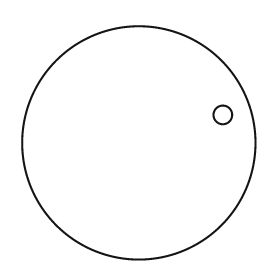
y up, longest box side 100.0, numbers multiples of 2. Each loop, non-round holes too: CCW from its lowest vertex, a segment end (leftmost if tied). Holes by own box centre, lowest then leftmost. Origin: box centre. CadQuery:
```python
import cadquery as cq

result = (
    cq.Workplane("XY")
    .moveTo(0.0, 0.0)
    .circle(50.0)
    .moveTo(36.0, 12.0)
    .circle(4.0)
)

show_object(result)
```